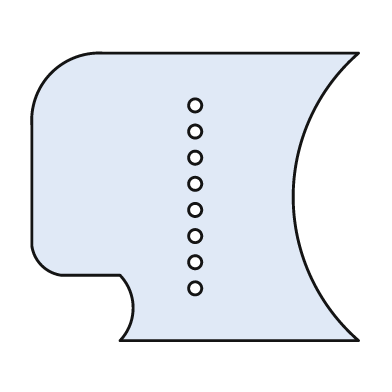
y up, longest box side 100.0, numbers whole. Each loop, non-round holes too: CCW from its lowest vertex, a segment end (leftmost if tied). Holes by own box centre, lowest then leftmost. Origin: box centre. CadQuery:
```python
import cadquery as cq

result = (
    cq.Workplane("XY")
    .moveTo(-23.0, -44.0)
    .lineTo(50.0, -44.0)
    .threePointArc((30.0, 0.0), (50.0, 44.0))
    .lineTo(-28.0, 44.0)
    .threePointArc((-44.0, 38.0), (-50.0, 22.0))
    .lineTo(-50.0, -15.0)
    .threePointArc((-47.0, -21.0), (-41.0, -24.0))
    .lineTo(-23.0, -24.0)
    .threePointArc((-19.0, -34.0), (-23.0, -44.0))
    .close()
    .moveTo(0.0, -28.0)
    .circle(2.0)
    .moveTo(0.0, -20.0)
    .circle(2.0)
    .moveTo(0.0, -12.0)
    .circle(2.0)
    .moveTo(0.0, -4.0)
    .circle(2.0)
    .moveTo(0.0, 4.0)
    .circle(2.0)
    .moveTo(0.0, 12.0)
    .circle(2.0)
    .moveTo(0.0, 20.0)
    .circle(2.0)
    .moveTo(0.0, 28.0)
    .circle(2.0)
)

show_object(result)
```